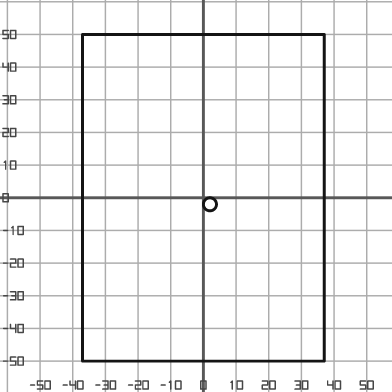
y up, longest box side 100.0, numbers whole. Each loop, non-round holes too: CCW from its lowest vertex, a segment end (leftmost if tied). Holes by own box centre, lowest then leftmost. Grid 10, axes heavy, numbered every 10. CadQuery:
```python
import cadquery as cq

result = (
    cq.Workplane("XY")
    .moveTo(-37.0, -50.0)
    .lineTo(37.0, -50.0)
    .lineTo(37.0, 50.0)
    .lineTo(-37.0, 50.0)
    .close()
    .moveTo(2.0, -2.0)
    .circle(2.0)
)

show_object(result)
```